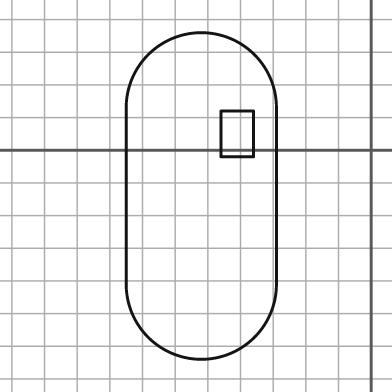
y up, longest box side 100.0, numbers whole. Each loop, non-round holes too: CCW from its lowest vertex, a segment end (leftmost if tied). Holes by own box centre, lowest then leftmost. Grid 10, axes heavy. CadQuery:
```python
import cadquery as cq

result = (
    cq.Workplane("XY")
    .moveTo(-75.0, -41.0)
    .threePointArc((-52.0, -64.0), (-29.0, -41.0))
    .lineTo(-29.0, 13.0)
    .threePointArc((-52.0, 36.0), (-75.0, 13.0))
    .close()
    .moveTo(-46.0, -2.0)
    .lineTo(-36.0, -2.0)
    .lineTo(-36.0, 12.0)
    .lineTo(-46.0, 12.0)
    .close()
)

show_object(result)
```